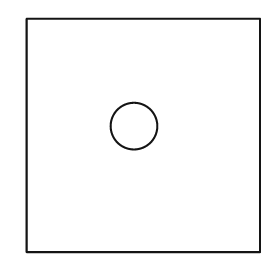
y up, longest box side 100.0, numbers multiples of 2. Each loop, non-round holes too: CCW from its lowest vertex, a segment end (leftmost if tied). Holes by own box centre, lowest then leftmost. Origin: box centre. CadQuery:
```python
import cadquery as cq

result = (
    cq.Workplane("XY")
    .moveTo(-50.0, -50.0)
    .lineTo(50.0, -50.0)
    .lineTo(50.0, 50.0)
    .lineTo(-50.0, 50.0)
    .close()
    .moveTo(-4.0, 4.0)
    .circle(10.0)
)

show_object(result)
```